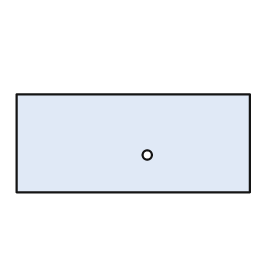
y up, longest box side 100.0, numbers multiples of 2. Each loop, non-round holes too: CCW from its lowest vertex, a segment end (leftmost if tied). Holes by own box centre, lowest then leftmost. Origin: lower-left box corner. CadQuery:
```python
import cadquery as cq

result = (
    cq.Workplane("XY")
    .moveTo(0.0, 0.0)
    .lineTo(100.0, 0.0)
    .lineTo(100.0, 42.0)
    .lineTo(0.0, 42.0)
    .close()
    .moveTo(56.0, 16.0)
    .circle(2.0)
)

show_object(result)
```